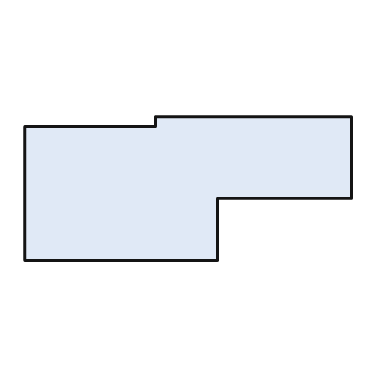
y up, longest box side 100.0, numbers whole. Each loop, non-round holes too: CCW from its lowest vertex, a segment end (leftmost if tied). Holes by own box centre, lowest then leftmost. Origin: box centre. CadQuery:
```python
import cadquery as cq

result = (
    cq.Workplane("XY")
    .moveTo(-50.0, -22.0)
    .lineTo(9.0, -22.0)
    .lineTo(9.0, -3.0)
    .lineTo(50.0, -3.0)
    .lineTo(50.0, 22.0)
    .lineTo(-10.0, 22.0)
    .lineTo(-10.0, 19.0)
    .lineTo(-50.0, 19.0)
    .close()
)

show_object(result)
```